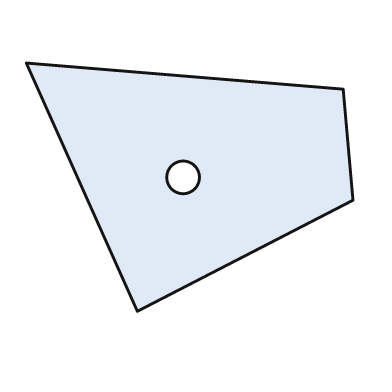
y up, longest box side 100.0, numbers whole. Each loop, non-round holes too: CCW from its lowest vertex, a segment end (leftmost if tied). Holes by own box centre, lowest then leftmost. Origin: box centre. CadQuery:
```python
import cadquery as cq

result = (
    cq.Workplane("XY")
    .moveTo(-16.0, -38.0)
    .lineTo(50.0, -4.0)
    .lineTo(47.0, 30.0)
    .lineTo(-50.0, 38.0)
    .close()
    .moveTo(-2.0, 3.0)
    .circle(5.0)
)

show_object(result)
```